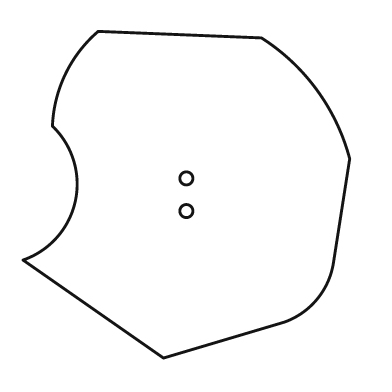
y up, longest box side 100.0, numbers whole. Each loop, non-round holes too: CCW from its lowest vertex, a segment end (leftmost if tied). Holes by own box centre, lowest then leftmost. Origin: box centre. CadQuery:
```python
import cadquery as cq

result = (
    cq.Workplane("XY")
    .moveTo(-7.0, -50.0)
    .lineTo(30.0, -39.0)
    .threePointArc((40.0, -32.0), (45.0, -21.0))
    .lineTo(50.0, 11.0)
    .threePointArc((40.0, 32.0), (23.0, 48.0))
    .lineTo(-27.0, 50.0)
    .threePointArc((-37.0, 37.0), (-41.0, 21.0))
    .threePointArc((-34.0, -2.0), (-50.0, -20.0))
    .close()
    .moveTo(0.0, -5.0)
    .circle(2.0)
    .moveTo(0.0, 5.0)
    .circle(2.0)
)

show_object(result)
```